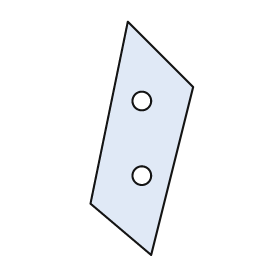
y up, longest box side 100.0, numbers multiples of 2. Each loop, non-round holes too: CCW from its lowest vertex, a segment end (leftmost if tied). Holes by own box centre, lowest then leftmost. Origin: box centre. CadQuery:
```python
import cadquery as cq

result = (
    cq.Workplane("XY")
    .moveTo(4.0, -50.0)
    .lineTo(22.0, 22.0)
    .lineTo(-6.0, 50.0)
    .lineTo(-22.0, -28.0)
    .close()
    .moveTo(0.0, -16.0)
    .circle(4.0)
    .moveTo(0.0, 16.0)
    .circle(4.0)
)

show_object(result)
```